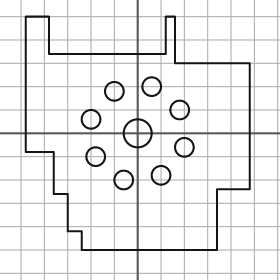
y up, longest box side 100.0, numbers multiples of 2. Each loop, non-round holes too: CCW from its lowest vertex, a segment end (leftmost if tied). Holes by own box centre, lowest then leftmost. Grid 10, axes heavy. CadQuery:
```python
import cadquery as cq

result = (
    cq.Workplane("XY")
    .moveTo(-24.0, -50.0)
    .lineTo(34.0, -50.0)
    .lineTo(34.0, -24.0)
    .lineTo(48.0, -24.0)
    .lineTo(48.0, 30.0)
    .lineTo(16.0, 30.0)
    .lineTo(16.0, 50.0)
    .lineTo(12.0, 50.0)
    .lineTo(12.0, 34.0)
    .lineTo(-38.0, 34.0)
    .lineTo(-38.0, 50.0)
    .lineTo(-48.0, 50.0)
    .lineTo(-48.0, -8.0)
    .lineTo(-36.0, -8.0)
    .lineTo(-36.0, -26.0)
    .lineTo(-30.0, -26.0)
    .lineTo(-30.0, -42.0)
    .lineTo(-24.0, -42.0)
    .close()
    .moveTo(-6.0, -20.0)
    .circle(4.0)
    .moveTo(10.0, -18.0)
    .circle(4.0)
    .moveTo(-18.0, -10.0)
    .circle(4.0)
    .moveTo(20.0, -6.0)
    .circle(4.0)
    .moveTo(0.0, 0.0)
    .circle(6.0)
    .moveTo(-20.0, 6.0)
    .circle(4.0)
    .moveTo(18.0, 10.0)
    .circle(4.0)
    .moveTo(-10.0, 18.0)
    .circle(4.0)
    .moveTo(6.0, 20.0)
    .circle(4.0)
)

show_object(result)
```